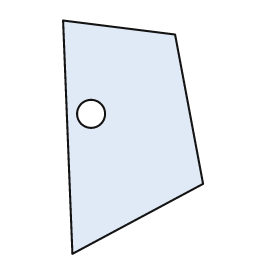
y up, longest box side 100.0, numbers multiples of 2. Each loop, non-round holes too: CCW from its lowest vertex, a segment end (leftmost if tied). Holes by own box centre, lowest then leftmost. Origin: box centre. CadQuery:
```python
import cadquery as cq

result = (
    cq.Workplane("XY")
    .moveTo(-26.0, -50.0)
    .lineTo(30.0, -20.0)
    .lineTo(18.0, 44.0)
    .lineTo(-30.0, 50.0)
    .close()
    .moveTo(-18.0, 10.0)
    .circle(6.0)
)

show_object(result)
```